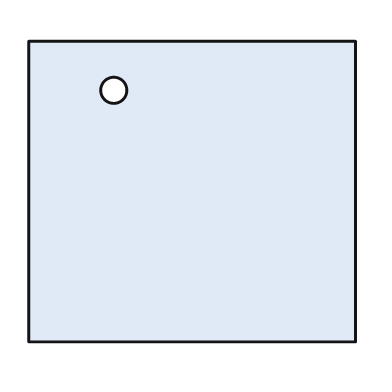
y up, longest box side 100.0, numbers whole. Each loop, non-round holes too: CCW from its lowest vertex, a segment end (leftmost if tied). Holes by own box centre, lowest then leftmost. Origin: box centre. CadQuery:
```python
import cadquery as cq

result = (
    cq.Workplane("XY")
    .moveTo(-50.0, -46.0)
    .lineTo(50.0, -46.0)
    .lineTo(50.0, 46.0)
    .lineTo(-50.0, 46.0)
    .close()
    .moveTo(-24.0, 31.0)
    .circle(4.0)
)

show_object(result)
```